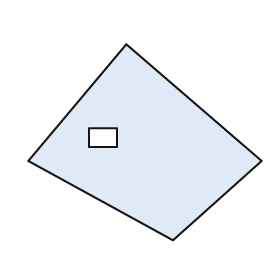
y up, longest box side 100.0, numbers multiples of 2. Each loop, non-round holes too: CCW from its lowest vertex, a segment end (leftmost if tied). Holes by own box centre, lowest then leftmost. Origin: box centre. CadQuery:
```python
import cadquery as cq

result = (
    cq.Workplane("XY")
    .moveTo(12.0, -42.0)
    .lineTo(50.0, -8.0)
    .lineTo(-8.0, 42.0)
    .lineTo(-50.0, -8.0)
    .close()
    .moveTo(-24.0, -2.0)
    .lineTo(-12.0, -2.0)
    .lineTo(-12.0, 6.0)
    .lineTo(-24.0, 6.0)
    .close()
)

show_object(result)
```